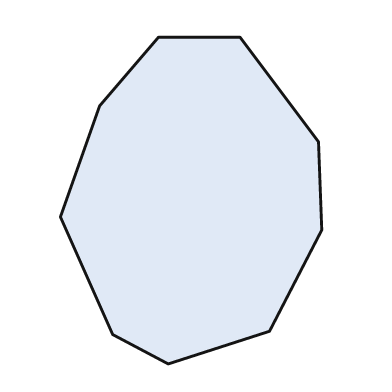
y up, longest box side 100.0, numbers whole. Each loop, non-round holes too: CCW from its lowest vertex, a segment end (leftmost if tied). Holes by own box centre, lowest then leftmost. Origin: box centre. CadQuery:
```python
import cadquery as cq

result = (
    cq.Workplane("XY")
    .moveTo(-7.0, -50.0)
    .lineTo(24.0, -40.0)
    .lineTo(40.0, -9.0)
    .lineTo(39.0, 18.0)
    .lineTo(15.0, 50.0)
    .lineTo(-10.0, 50.0)
    .lineTo(-28.0, 29.0)
    .lineTo(-40.0, -5.0)
    .lineTo(-24.0, -41.0)
    .close()
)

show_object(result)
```